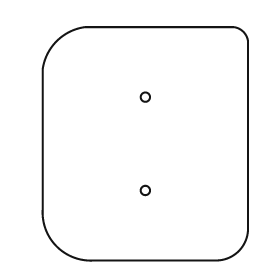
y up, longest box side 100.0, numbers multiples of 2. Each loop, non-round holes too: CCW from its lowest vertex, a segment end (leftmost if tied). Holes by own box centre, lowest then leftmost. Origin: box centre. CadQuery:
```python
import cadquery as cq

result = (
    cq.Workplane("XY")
    .moveTo(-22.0, -50.0)
    .lineTo(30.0, -50.0)
    .threePointArc((40.0, -46.0), (44.0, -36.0))
    .lineTo(44.0, 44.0)
    .threePointArc((42.0, 48.0), (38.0, 50.0))
    .lineTo(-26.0, 50.0)
    .threePointArc((-38.0, 44.0), (-44.0, 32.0))
    .lineTo(-44.0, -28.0)
    .threePointArc((-38.0, -44.0), (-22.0, -50.0))
    .close()
    .moveTo(0.0, -20.0)
    .circle(2.0)
    .moveTo(0.0, 20.0)
    .circle(2.0)
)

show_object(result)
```